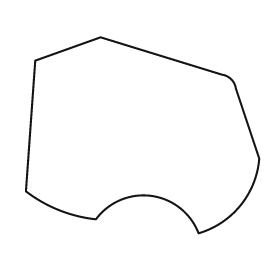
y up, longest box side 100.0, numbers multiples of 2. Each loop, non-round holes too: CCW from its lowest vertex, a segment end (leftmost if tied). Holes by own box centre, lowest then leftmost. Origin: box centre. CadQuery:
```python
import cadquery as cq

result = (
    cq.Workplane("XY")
    .moveTo(24.0, -42.0)
    .threePointArc((42.0, -30.0), (50.0, -10.0))
    .lineTo(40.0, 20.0)
    .threePointArc((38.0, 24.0), (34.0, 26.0))
    .lineTo(-18.0, 42.0)
    .lineTo(-46.0, 32.0)
    .lineTo(-50.0, -24.0)
    .threePointArc((-36.0, -32.0), (-20.0, -36.0))
    .threePointArc((4.0, -26.0), (24.0, -42.0))
    .close()
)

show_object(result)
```